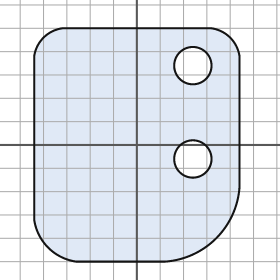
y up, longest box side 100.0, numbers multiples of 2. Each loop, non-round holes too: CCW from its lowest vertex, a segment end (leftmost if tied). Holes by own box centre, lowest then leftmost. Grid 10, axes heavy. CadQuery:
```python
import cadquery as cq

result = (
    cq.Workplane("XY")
    .moveTo(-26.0, -50.0)
    .lineTo(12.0, -50.0)
    .threePointArc((34.0, -40.0), (44.0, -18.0))
    .lineTo(44.0, 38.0)
    .threePointArc((40.0, 46.0), (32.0, 50.0))
    .lineTo(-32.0, 50.0)
    .threePointArc((-40.0, 46.0), (-44.0, 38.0))
    .lineTo(-44.0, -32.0)
    .threePointArc((-38.0, -44.0), (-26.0, -50.0))
    .close()
    .moveTo(24.0, -6.0)
    .circle(8.0)
    .moveTo(24.0, 34.0)
    .circle(8.0)
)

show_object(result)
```